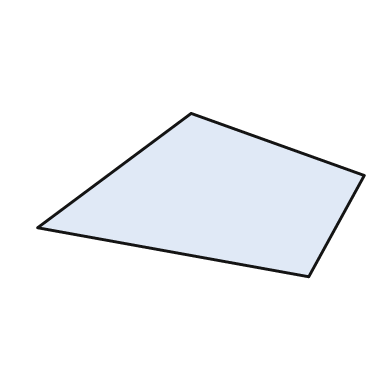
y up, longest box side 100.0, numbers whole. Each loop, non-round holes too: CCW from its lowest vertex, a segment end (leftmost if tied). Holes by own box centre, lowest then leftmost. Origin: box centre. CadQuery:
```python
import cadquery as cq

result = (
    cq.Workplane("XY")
    .moveTo(33.0, -25.0)
    .lineTo(50.0, 6.0)
    .lineTo(-3.0, 25.0)
    .lineTo(-50.0, -10.0)
    .close()
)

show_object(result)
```